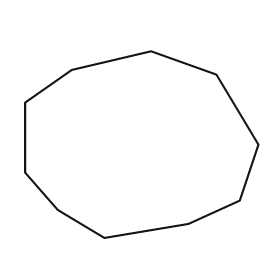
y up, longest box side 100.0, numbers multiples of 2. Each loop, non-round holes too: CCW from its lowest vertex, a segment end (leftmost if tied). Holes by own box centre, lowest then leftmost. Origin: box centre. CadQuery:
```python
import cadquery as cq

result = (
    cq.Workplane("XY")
    .moveTo(-16.0, -40.0)
    .lineTo(20.0, -34.0)
    .lineTo(42.0, -24.0)
    .lineTo(50.0, 0.0)
    .lineTo(32.0, 30.0)
    .lineTo(4.0, 40.0)
    .lineTo(-30.0, 32.0)
    .lineTo(-50.0, 18.0)
    .lineTo(-50.0, -12.0)
    .lineTo(-36.0, -28.0)
    .close()
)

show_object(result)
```